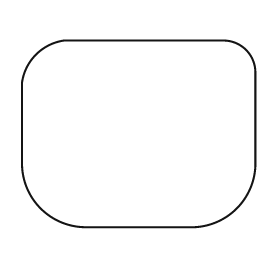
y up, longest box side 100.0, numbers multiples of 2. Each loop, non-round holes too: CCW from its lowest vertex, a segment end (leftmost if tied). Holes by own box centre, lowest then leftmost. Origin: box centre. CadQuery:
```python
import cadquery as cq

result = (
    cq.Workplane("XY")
    .moveTo(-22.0, -40.0)
    .lineTo(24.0, -40.0)
    .threePointArc((42.0, -32.0), (50.0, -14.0))
    .lineTo(50.0, 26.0)
    .threePointArc((46.0, 36.0), (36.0, 40.0))
    .lineTo(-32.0, 40.0)
    .threePointArc((-44.0, 34.0), (-50.0, 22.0))
    .lineTo(-50.0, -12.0)
    .threePointArc((-42.0, -32.0), (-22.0, -40.0))
    .close()
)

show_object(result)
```